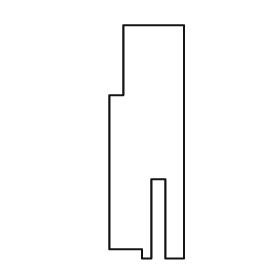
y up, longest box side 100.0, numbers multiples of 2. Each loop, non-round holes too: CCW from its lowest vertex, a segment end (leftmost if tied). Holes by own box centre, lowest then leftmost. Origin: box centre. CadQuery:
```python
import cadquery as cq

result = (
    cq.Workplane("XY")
    .moveTo(-2.0, -50.0)
    .lineTo(2.0, -50.0)
    .lineTo(2.0, -16.0)
    .lineTo(8.0, -16.0)
    .lineTo(8.0, -50.0)
    .lineTo(16.0, -50.0)
    .lineTo(16.0, 50.0)
    .lineTo(-10.0, 50.0)
    .lineTo(-10.0, 20.0)
    .lineTo(-16.0, 20.0)
    .lineTo(-16.0, -46.0)
    .lineTo(-2.0, -46.0)
    .close()
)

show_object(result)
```